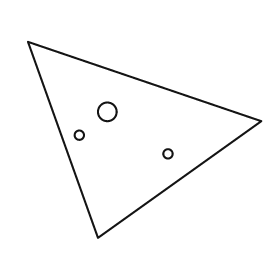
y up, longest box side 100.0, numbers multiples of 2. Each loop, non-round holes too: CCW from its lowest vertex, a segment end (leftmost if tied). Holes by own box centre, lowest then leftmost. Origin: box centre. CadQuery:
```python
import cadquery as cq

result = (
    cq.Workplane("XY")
    .moveTo(-20.0, -42.0)
    .lineTo(50.0, 8.0)
    .lineTo(-50.0, 42.0)
    .close()
    .moveTo(10.0, -6.0)
    .circle(2.0)
    .moveTo(-28.0, 2.0)
    .circle(2.0)
    .moveTo(-16.0, 12.0)
    .circle(4.0)
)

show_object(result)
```